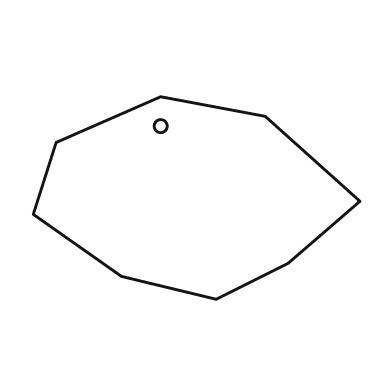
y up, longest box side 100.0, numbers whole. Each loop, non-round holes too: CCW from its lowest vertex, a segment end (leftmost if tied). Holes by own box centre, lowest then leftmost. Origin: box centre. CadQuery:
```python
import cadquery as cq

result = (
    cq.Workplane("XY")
    .moveTo(6.0, -31.0)
    .lineTo(28.0, -20.0)
    .lineTo(50.0, -1.0)
    .lineTo(21.0, 25.0)
    .lineTo(-11.0, 31.0)
    .lineTo(-43.0, 17.0)
    .lineTo(-50.0, -5.0)
    .lineTo(-23.0, -24.0)
    .close()
    .moveTo(-11.0, 22.0)
    .circle(2.0)
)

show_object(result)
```